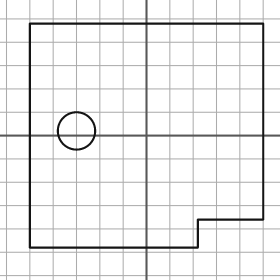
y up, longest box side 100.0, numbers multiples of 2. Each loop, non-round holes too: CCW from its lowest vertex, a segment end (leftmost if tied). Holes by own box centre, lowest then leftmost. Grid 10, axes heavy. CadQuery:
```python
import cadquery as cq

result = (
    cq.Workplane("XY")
    .moveTo(-50.0, -48.0)
    .lineTo(22.0, -48.0)
    .lineTo(22.0, -36.0)
    .lineTo(50.0, -36.0)
    .lineTo(50.0, 48.0)
    .lineTo(-50.0, 48.0)
    .close()
    .moveTo(-30.0, 2.0)
    .circle(8.0)
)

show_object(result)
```